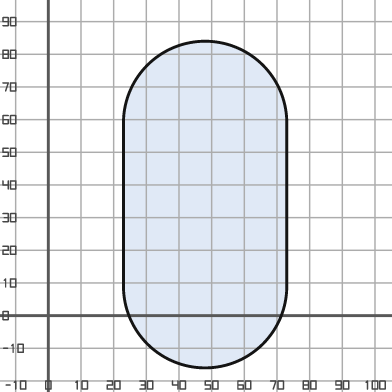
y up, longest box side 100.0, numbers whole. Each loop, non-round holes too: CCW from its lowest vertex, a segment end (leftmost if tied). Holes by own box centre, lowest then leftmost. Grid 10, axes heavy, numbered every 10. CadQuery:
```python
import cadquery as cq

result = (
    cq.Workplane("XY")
    .moveTo(23.0, 9.0)
    .threePointArc((48.0, -16.0), (73.0, 9.0))
    .lineTo(73.0, 59.0)
    .threePointArc((48.0, 84.0), (23.0, 59.0))
    .close()
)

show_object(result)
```